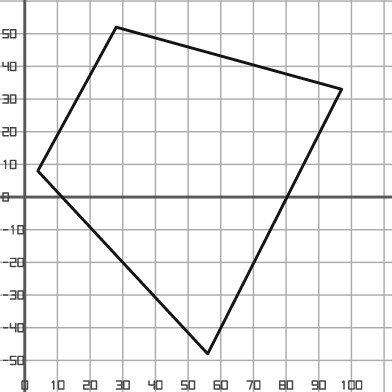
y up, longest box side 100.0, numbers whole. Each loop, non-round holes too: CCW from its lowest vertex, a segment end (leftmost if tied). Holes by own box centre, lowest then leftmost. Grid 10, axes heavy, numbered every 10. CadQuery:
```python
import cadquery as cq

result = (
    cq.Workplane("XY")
    .moveTo(56.0, -48.0)
    .lineTo(97.0, 33.0)
    .lineTo(28.0, 52.0)
    .lineTo(4.0, 8.0)
    .close()
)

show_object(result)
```